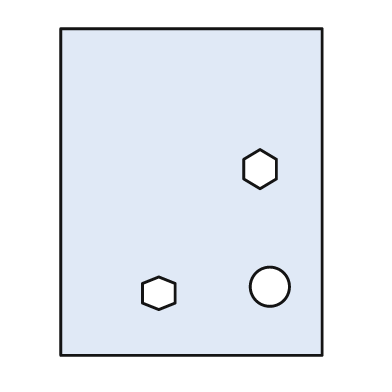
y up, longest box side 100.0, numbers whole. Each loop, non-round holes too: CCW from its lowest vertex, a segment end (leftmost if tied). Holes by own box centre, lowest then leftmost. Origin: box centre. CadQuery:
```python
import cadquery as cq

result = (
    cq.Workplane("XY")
    .moveTo(-40.0, -50.0)
    .lineTo(40.0, -50.0)
    .lineTo(40.0, 50.0)
    .lineTo(-40.0, 50.0)
    .close()
    .moveTo(-10.0, -36.0)
    .lineTo(-5.0, -34.0)
    .lineTo(-5.0, -28.0)
    .lineTo(-10.0, -26.0)
    .lineTo(-15.0, -28.0)
    .lineTo(-15.0, -34.0)
    .close()
    .moveTo(24.0, -29.0)
    .circle(6.0)
    .moveTo(21.0, 1.0)
    .lineTo(26.0, 4.0)
    .lineTo(26.0, 10.0)
    .lineTo(21.0, 13.0)
    .lineTo(16.0, 10.0)
    .lineTo(16.0, 4.0)
    .close()
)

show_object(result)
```